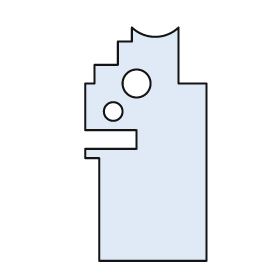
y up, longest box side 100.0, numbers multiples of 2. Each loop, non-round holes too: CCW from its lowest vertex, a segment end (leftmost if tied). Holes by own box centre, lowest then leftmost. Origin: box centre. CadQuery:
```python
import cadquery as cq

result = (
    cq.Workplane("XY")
    .moveTo(-20.0, -50.0)
    .lineTo(26.0, -50.0)
    .lineTo(26.0, 26.0)
    .lineTo(14.0, 26.0)
    .lineTo(14.0, 50.0)
    .threePointArc((4.0, 46.0), (-6.0, 50.0))
    .lineTo(-6.0, 44.0)
    .lineTo(-12.0, 44.0)
    .lineTo(-12.0, 34.0)
    .lineTo(-22.0, 34.0)
    .lineTo(-22.0, 26.0)
    .lineTo(-26.0, 26.0)
    .lineTo(-26.0, 6.0)
    .lineTo(-4.0, 6.0)
    .lineTo(-4.0, -2.0)
    .lineTo(-26.0, -2.0)
    .lineTo(-26.0, -6.0)
    .lineTo(-20.0, -6.0)
    .close()
    .moveTo(-14.0, 14.0)
    .circle(4.0)
    .moveTo(-4.0, 26.0)
    .circle(6.0)
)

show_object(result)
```